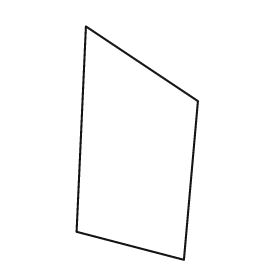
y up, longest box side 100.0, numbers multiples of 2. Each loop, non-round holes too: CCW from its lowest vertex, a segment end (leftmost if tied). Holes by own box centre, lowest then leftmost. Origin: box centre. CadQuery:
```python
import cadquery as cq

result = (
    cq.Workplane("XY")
    .moveTo(20.0, -50.0)
    .lineTo(26.0, 18.0)
    .lineTo(-22.0, 50.0)
    .lineTo(-26.0, -38.0)
    .close()
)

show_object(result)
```